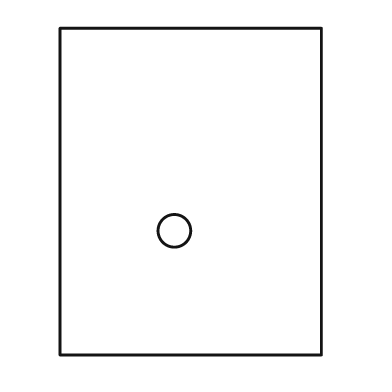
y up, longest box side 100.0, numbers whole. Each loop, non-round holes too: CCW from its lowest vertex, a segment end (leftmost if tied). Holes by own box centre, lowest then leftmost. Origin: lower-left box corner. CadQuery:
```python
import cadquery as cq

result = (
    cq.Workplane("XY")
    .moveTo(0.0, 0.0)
    .lineTo(80.0, 0.0)
    .lineTo(80.0, 100.0)
    .lineTo(0.0, 100.0)
    .close()
    .moveTo(35.0, 38.0)
    .circle(5.0)
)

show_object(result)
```